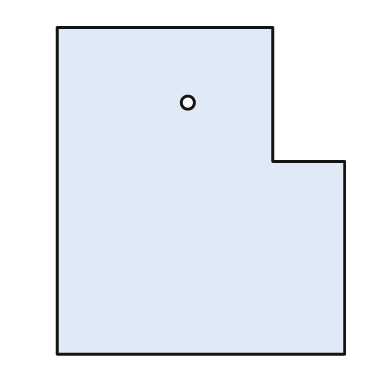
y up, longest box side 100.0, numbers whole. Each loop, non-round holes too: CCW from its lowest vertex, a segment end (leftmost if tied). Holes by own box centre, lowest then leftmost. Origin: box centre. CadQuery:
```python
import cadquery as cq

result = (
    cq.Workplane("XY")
    .moveTo(-44.0, -50.0)
    .lineTo(44.0, -50.0)
    .lineTo(44.0, 9.0)
    .lineTo(22.0, 9.0)
    .lineTo(22.0, 50.0)
    .lineTo(-44.0, 50.0)
    .close()
    .moveTo(-4.0, 27.0)
    .circle(2.0)
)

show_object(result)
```